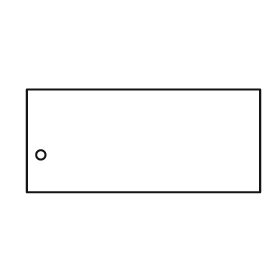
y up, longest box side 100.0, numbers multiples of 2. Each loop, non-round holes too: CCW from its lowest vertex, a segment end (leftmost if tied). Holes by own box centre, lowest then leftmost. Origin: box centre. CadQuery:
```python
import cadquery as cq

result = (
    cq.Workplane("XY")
    .moveTo(-50.0, -22.0)
    .lineTo(50.0, -22.0)
    .lineTo(50.0, 22.0)
    .lineTo(-50.0, 22.0)
    .close()
    .moveTo(-44.0, -6.0)
    .circle(2.0)
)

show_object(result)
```